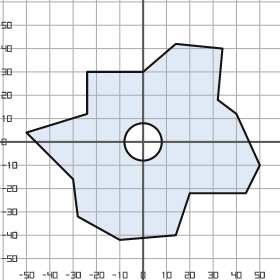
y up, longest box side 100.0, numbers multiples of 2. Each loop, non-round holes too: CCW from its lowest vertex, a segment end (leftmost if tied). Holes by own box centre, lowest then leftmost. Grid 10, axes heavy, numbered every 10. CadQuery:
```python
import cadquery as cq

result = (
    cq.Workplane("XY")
    .moveTo(-10.0, -42.0)
    .lineTo(14.0, -40.0)
    .lineTo(20.0, -22.0)
    .lineTo(44.0, -22.0)
    .lineTo(50.0, -10.0)
    .lineTo(40.0, 12.0)
    .lineTo(32.0, 18.0)
    .lineTo(34.0, 40.0)
    .lineTo(14.0, 42.0)
    .lineTo(0.0, 30.0)
    .lineTo(-24.0, 30.0)
    .lineTo(-24.0, 12.0)
    .lineTo(-50.0, 4.0)
    .lineTo(-30.0, -16.0)
    .lineTo(-28.0, -32.0)
    .close()
    .moveTo(0.0, 0.0)
    .circle(8.0)
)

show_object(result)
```